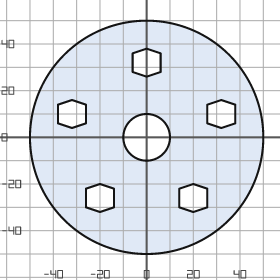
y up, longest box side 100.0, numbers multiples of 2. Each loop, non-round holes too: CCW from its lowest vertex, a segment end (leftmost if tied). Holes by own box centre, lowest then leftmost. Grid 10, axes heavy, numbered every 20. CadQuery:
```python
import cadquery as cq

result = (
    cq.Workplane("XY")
    .moveTo(0.0, 0.0)
    .circle(50.0)
    .moveTo(-20.0, -32.0)
    .lineTo(-14.0, -30.0)
    .lineTo(-14.0, -22.0)
    .lineTo(-20.0, -20.0)
    .lineTo(-26.0, -22.0)
    .lineTo(-26.0, -30.0)
    .close()
    .moveTo(20.0, -32.0)
    .lineTo(26.0, -30.0)
    .lineTo(26.0, -22.0)
    .lineTo(20.0, -20.0)
    .lineTo(14.0, -22.0)
    .lineTo(14.0, -30.0)
    .close()
    .moveTo(0.0, 0.0)
    .circle(10.0)
    .moveTo(-32.0, 4.0)
    .lineTo(-26.0, 6.0)
    .lineTo(-26.0, 14.0)
    .lineTo(-32.0, 16.0)
    .lineTo(-38.0, 14.0)
    .lineTo(-38.0, 6.0)
    .close()
    .moveTo(32.0, 4.0)
    .lineTo(38.0, 6.0)
    .lineTo(38.0, 14.0)
    .lineTo(32.0, 16.0)
    .lineTo(26.0, 14.0)
    .lineTo(26.0, 6.0)
    .close()
    .moveTo(0.0, 26.0)
    .lineTo(6.0, 28.0)
    .lineTo(6.0, 36.0)
    .lineTo(0.0, 38.0)
    .lineTo(-6.0, 36.0)
    .lineTo(-6.0, 28.0)
    .close()
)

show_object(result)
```